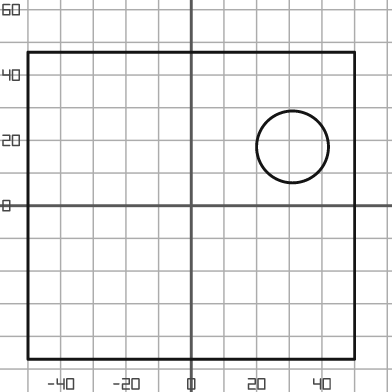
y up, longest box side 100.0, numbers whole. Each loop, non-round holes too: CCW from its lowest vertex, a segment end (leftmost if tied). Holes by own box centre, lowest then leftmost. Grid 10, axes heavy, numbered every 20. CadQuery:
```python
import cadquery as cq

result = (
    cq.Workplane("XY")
    .moveTo(-50.0, -47.0)
    .lineTo(50.0, -47.0)
    .lineTo(50.0, 47.0)
    .lineTo(-50.0, 47.0)
    .close()
    .moveTo(31.0, 18.0)
    .circle(11.0)
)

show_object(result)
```